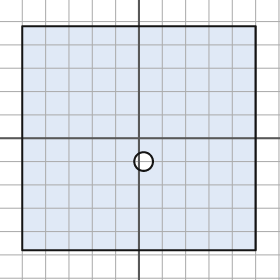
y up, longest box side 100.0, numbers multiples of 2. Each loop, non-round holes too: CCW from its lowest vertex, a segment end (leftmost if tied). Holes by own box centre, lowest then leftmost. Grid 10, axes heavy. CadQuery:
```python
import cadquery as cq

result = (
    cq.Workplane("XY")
    .moveTo(-50.0, -48.0)
    .lineTo(50.0, -48.0)
    .lineTo(50.0, 48.0)
    .lineTo(-50.0, 48.0)
    .close()
    .moveTo(2.0, -10.0)
    .circle(4.0)
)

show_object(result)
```